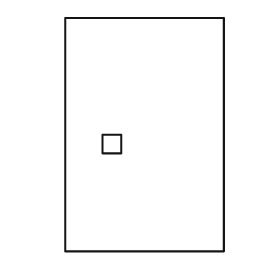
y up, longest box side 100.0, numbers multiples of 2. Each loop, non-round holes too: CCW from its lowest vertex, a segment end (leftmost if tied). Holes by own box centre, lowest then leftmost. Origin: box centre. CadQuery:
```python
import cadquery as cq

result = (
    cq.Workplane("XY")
    .moveTo(-34.0, -50.0)
    .lineTo(34.0, -50.0)
    .lineTo(34.0, 50.0)
    .lineTo(-34.0, 50.0)
    .close()
    .moveTo(-18.0, -8.0)
    .lineTo(-10.0, -8.0)
    .lineTo(-10.0, 0.0)
    .lineTo(-18.0, 0.0)
    .close()
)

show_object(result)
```